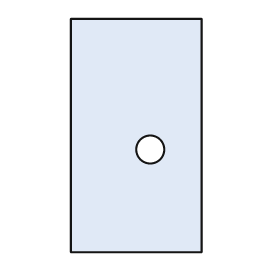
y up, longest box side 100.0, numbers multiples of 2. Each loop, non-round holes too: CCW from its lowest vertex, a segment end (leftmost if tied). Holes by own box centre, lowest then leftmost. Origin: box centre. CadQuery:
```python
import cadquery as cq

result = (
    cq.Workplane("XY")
    .moveTo(-28.0, -50.0)
    .lineTo(28.0, -50.0)
    .lineTo(28.0, 50.0)
    .lineTo(-28.0, 50.0)
    .close()
    .moveTo(6.0, -6.0)
    .circle(6.0)
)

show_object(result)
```